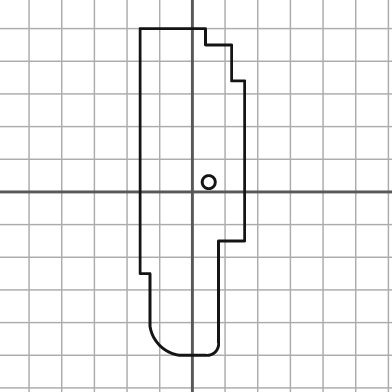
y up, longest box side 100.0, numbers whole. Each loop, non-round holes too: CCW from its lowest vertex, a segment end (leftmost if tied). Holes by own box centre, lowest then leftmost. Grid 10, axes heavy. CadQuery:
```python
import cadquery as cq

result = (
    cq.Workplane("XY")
    .moveTo(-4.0, -50.0)
    .lineTo(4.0, -50.0)
    .threePointArc((7.0, -49.0), (8.0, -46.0))
    .lineTo(8.0, -15.0)
    .lineTo(16.0, -15.0)
    .lineTo(16.0, 34.0)
    .lineTo(12.0, 34.0)
    .lineTo(12.0, 45.0)
    .lineTo(4.0, 45.0)
    .lineTo(4.0, 50.0)
    .lineTo(-16.0, 50.0)
    .lineTo(-16.0, -25.0)
    .lineTo(-13.0, -25.0)
    .lineTo(-13.0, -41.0)
    .threePointArc((-10.0, -47.0), (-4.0, -50.0))
    .close()
    .moveTo(5.0, 3.0)
    .circle(2.0)
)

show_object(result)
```